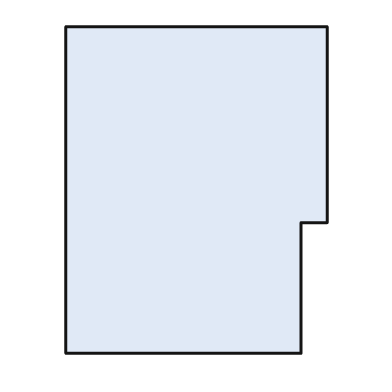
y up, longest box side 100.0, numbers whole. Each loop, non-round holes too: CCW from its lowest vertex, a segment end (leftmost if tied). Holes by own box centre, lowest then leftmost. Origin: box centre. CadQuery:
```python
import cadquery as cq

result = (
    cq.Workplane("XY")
    .moveTo(-40.0, -50.0)
    .lineTo(32.0, -50.0)
    .lineTo(32.0, -10.0)
    .lineTo(40.0, -10.0)
    .lineTo(40.0, 50.0)
    .lineTo(-40.0, 50.0)
    .close()
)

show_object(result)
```